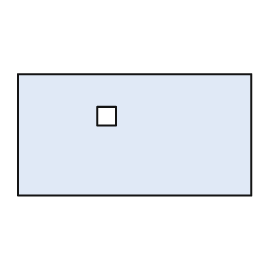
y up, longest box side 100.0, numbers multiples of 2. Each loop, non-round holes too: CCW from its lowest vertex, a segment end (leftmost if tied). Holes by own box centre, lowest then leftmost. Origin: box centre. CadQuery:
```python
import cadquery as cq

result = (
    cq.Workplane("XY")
    .moveTo(-50.0, -26.0)
    .lineTo(50.0, -26.0)
    .lineTo(50.0, 26.0)
    .lineTo(-50.0, 26.0)
    .close()
    .moveTo(-16.0, 4.0)
    .lineTo(-8.0, 4.0)
    .lineTo(-8.0, 12.0)
    .lineTo(-16.0, 12.0)
    .close()
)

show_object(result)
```